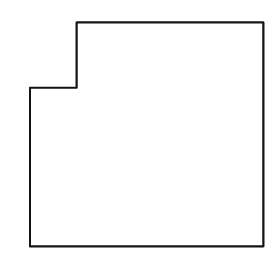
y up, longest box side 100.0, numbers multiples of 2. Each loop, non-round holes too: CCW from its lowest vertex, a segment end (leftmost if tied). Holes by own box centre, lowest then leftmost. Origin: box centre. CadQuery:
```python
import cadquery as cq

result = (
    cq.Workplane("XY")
    .moveTo(-50.0, -48.0)
    .lineTo(50.0, -48.0)
    .lineTo(50.0, 48.0)
    .lineTo(-30.0, 48.0)
    .lineTo(-30.0, 20.0)
    .lineTo(-50.0, 20.0)
    .close()
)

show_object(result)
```